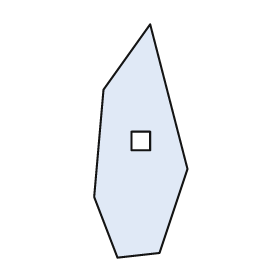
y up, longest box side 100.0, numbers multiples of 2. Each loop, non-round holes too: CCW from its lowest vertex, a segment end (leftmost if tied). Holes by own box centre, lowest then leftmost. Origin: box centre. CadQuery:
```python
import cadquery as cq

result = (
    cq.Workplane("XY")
    .moveTo(-10.0, -50.0)
    .lineTo(8.0, -48.0)
    .lineTo(20.0, -12.0)
    .lineTo(4.0, 50.0)
    .lineTo(-16.0, 22.0)
    .lineTo(-20.0, -24.0)
    .close()
    .moveTo(-4.0, -4.0)
    .lineTo(4.0, -4.0)
    .lineTo(4.0, 4.0)
    .lineTo(-4.0, 4.0)
    .close()
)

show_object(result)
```